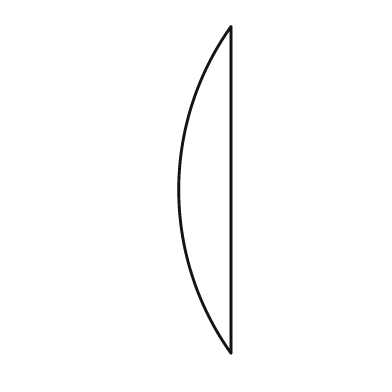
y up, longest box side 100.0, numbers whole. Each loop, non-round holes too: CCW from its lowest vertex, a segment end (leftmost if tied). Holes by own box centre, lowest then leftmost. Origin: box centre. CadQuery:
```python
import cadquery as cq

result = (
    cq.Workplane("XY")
    .moveTo(8.0, -50.0)
    .lineTo(8.0, 50.0)
    .threePointArc((-8.0, 0.0), (8.0, -50.0))
    .close()
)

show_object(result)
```